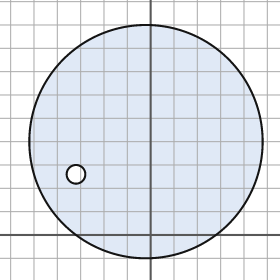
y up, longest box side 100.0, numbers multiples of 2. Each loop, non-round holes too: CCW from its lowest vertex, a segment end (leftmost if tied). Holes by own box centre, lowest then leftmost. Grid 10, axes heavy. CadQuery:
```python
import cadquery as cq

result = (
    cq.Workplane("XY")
    .moveTo(-2.0, 40.0)
    .circle(50.0)
    .moveTo(-32.0, 26.0)
    .circle(4.0)
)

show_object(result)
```